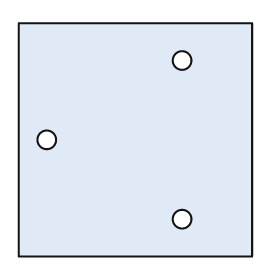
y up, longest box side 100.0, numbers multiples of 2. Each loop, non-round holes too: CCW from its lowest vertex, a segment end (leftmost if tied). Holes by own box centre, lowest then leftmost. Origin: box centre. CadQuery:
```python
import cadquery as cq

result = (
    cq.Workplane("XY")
    .moveTo(-50.0, -50.0)
    .lineTo(50.0, -50.0)
    .lineTo(50.0, 50.0)
    .lineTo(-50.0, 50.0)
    .close()
    .moveTo(20.0, -34.0)
    .circle(4.0)
    .moveTo(-38.0, 0.0)
    .circle(4.0)
    .moveTo(20.0, 34.0)
    .circle(4.0)
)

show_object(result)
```